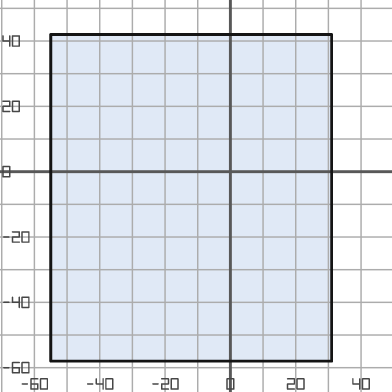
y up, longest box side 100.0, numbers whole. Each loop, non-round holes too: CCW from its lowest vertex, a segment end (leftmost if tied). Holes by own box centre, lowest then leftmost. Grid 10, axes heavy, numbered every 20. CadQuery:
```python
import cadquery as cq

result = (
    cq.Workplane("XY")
    .moveTo(-55.0, -58.0)
    .lineTo(31.0, -58.0)
    .lineTo(31.0, 42.0)
    .lineTo(-55.0, 42.0)
    .close()
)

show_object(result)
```